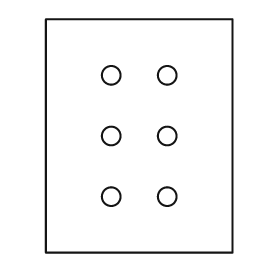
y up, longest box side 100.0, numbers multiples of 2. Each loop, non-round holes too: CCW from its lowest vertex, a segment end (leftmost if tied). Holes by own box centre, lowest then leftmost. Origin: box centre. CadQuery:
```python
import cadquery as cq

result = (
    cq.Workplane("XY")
    .moveTo(-40.0, -50.0)
    .lineTo(40.0, -50.0)
    .lineTo(40.0, 50.0)
    .lineTo(-40.0, 50.0)
    .close()
    .moveTo(-12.0, -26.0)
    .circle(4.0)
    .moveTo(12.0, -26.0)
    .circle(4.0)
    .moveTo(-12.0, 0.0)
    .circle(4.0)
    .moveTo(12.0, 0.0)
    .circle(4.0)
    .moveTo(-12.0, 26.0)
    .circle(4.0)
    .moveTo(12.0, 26.0)
    .circle(4.0)
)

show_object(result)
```